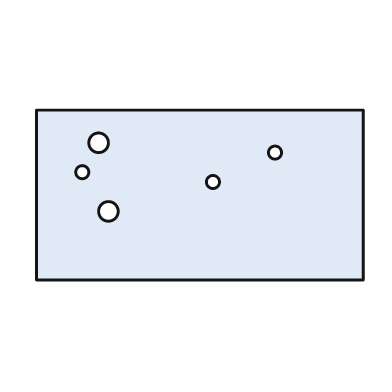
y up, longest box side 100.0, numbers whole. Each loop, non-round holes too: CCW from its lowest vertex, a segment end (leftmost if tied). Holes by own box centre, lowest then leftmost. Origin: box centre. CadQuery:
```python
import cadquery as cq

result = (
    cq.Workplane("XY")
    .moveTo(-50.0, -26.0)
    .lineTo(50.0, -26.0)
    .lineTo(50.0, 26.0)
    .lineTo(-50.0, 26.0)
    .close()
    .moveTo(-28.0, -5.0)
    .circle(3.0)
    .moveTo(4.0, 4.0)
    .circle(2.0)
    .moveTo(-36.0, 7.0)
    .circle(2.0)
    .moveTo(23.0, 13.0)
    .circle(2.0)
    .moveTo(-31.0, 16.0)
    .circle(3.0)
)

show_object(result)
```